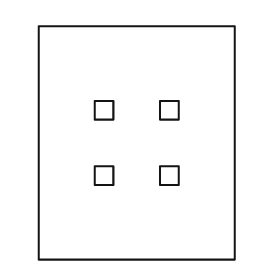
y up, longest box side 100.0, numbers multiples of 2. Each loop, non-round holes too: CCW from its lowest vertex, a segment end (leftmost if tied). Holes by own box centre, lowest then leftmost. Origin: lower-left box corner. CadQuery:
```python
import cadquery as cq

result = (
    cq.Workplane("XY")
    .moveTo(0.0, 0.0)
    .lineTo(84.0, 0.0)
    .lineTo(84.0, 100.0)
    .lineTo(0.0, 100.0)
    .close()
    .moveTo(24.0, 32.0)
    .lineTo(32.0, 32.0)
    .lineTo(32.0, 40.0)
    .lineTo(24.0, 40.0)
    .close()
    .moveTo(52.0, 32.0)
    .lineTo(60.0, 32.0)
    .lineTo(60.0, 40.0)
    .lineTo(52.0, 40.0)
    .close()
    .moveTo(24.0, 60.0)
    .lineTo(32.0, 60.0)
    .lineTo(32.0, 68.0)
    .lineTo(24.0, 68.0)
    .close()
    .moveTo(52.0, 60.0)
    .lineTo(60.0, 60.0)
    .lineTo(60.0, 68.0)
    .lineTo(52.0, 68.0)
    .close()
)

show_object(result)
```